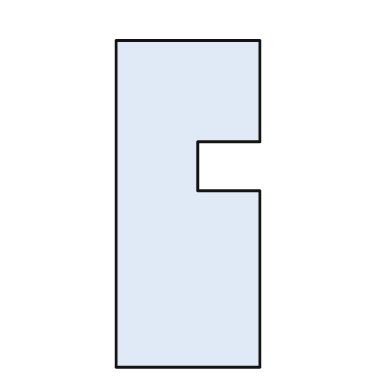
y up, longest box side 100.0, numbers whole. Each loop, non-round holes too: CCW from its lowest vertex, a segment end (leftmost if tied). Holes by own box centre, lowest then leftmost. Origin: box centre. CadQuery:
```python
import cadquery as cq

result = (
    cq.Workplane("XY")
    .moveTo(-22.0, -50.0)
    .lineTo(22.0, -50.0)
    .lineTo(22.0, 4.0)
    .lineTo(3.0, 4.0)
    .lineTo(3.0, 19.0)
    .lineTo(22.0, 19.0)
    .lineTo(22.0, 50.0)
    .lineTo(-22.0, 50.0)
    .close()
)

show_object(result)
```